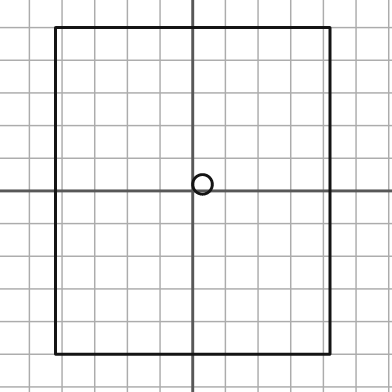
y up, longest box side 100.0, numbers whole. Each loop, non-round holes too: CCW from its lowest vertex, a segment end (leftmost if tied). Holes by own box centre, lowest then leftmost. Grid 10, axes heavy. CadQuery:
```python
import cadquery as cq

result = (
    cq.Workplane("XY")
    .moveTo(-42.0, -50.0)
    .lineTo(42.0, -50.0)
    .lineTo(42.0, 50.0)
    .lineTo(-42.0, 50.0)
    .close()
    .moveTo(3.0, 2.0)
    .circle(3.0)
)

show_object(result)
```